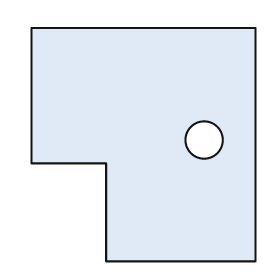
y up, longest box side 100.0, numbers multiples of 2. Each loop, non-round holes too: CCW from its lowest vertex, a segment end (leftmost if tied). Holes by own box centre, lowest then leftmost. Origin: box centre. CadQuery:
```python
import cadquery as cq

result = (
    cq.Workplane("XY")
    .moveTo(-16.0, -50.0)
    .lineTo(48.0, -50.0)
    .lineTo(48.0, 50.0)
    .lineTo(-48.0, 50.0)
    .lineTo(-48.0, -8.0)
    .lineTo(-16.0, -8.0)
    .close()
    .moveTo(26.0, 2.0)
    .circle(8.0)
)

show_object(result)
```